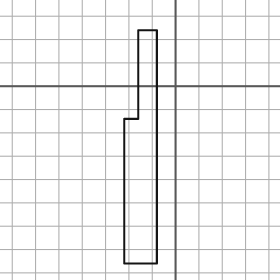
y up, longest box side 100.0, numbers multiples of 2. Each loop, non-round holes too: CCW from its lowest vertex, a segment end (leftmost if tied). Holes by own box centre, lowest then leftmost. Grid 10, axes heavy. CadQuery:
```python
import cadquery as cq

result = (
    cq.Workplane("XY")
    .moveTo(-22.0, -76.0)
    .lineTo(-8.0, -76.0)
    .lineTo(-8.0, 24.0)
    .lineTo(-16.0, 24.0)
    .lineTo(-16.0, -14.0)
    .lineTo(-22.0, -14.0)
    .close()
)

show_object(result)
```